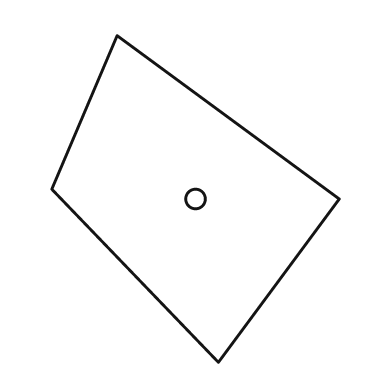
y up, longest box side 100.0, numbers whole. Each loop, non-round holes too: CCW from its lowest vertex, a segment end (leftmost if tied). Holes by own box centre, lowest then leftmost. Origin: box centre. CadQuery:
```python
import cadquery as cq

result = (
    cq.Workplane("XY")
    .moveTo(7.0, -50.0)
    .lineTo(44.0, 0.0)
    .lineTo(-24.0, 50.0)
    .lineTo(-44.0, 3.0)
    .close()
    .moveTo(0.0, 0.0)
    .circle(3.0)
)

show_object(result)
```